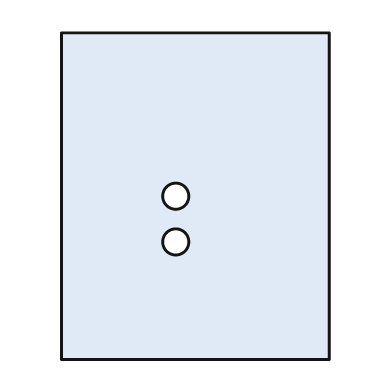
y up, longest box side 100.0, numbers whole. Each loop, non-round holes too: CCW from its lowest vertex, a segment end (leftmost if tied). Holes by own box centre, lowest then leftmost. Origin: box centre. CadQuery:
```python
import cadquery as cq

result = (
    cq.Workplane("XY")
    .moveTo(-41.0, -50.0)
    .lineTo(41.0, -50.0)
    .lineTo(41.0, 50.0)
    .lineTo(-41.0, 50.0)
    .close()
    .moveTo(-6.0, -14.0)
    .circle(4.0)
    .moveTo(-6.0, 0.0)
    .circle(4.0)
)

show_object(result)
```